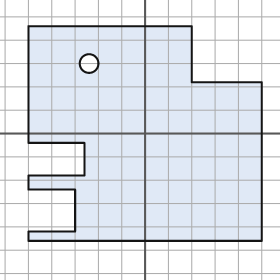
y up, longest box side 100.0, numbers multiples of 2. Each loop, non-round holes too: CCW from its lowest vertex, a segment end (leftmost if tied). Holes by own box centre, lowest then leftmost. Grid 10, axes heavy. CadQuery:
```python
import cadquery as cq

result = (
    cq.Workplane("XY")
    .moveTo(-50.0, -46.0)
    .lineTo(50.0, -46.0)
    .lineTo(50.0, 22.0)
    .lineTo(20.0, 22.0)
    .lineTo(20.0, 46.0)
    .lineTo(-50.0, 46.0)
    .lineTo(-50.0, -4.0)
    .lineTo(-26.0, -4.0)
    .lineTo(-26.0, -18.0)
    .lineTo(-50.0, -18.0)
    .lineTo(-50.0, -24.0)
    .lineTo(-30.0, -24.0)
    .lineTo(-30.0, -42.0)
    .lineTo(-50.0, -42.0)
    .close()
    .moveTo(-24.0, 30.0)
    .circle(4.0)
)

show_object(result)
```